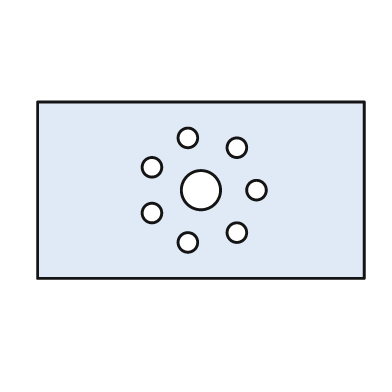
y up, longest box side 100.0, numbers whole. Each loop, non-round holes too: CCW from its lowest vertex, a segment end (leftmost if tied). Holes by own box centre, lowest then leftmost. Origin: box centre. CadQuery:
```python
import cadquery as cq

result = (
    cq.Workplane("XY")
    .moveTo(-50.0, -27.0)
    .lineTo(50.0, -27.0)
    .lineTo(50.0, 27.0)
    .lineTo(-50.0, 27.0)
    .close()
    .moveTo(-4.0, -16.0)
    .circle(3.0)
    .moveTo(11.0, -13.0)
    .circle(3.0)
    .moveTo(-15.0, -7.0)
    .circle(3.0)
    .moveTo(0.0, 0.0)
    .circle(6.0)
    .moveTo(17.0, 0.0)
    .circle(3.0)
    .moveTo(-15.0, 7.0)
    .circle(3.0)
    .moveTo(11.0, 13.0)
    .circle(3.0)
    .moveTo(-4.0, 16.0)
    .circle(3.0)
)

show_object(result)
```